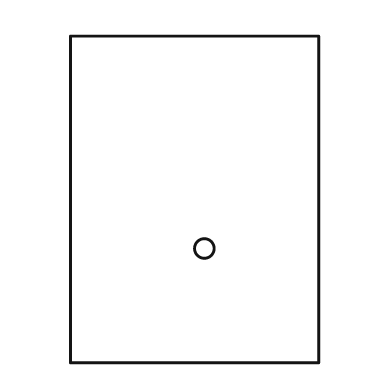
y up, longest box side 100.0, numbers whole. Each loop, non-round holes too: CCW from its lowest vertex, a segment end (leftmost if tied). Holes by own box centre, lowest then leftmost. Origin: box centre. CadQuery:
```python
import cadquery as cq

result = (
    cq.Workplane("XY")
    .moveTo(-38.0, -50.0)
    .lineTo(38.0, -50.0)
    .lineTo(38.0, 50.0)
    .lineTo(-38.0, 50.0)
    .close()
    .moveTo(3.0, -15.0)
    .circle(3.0)
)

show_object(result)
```